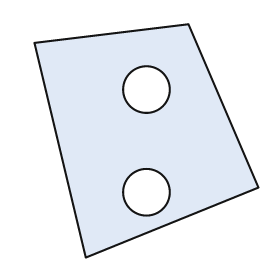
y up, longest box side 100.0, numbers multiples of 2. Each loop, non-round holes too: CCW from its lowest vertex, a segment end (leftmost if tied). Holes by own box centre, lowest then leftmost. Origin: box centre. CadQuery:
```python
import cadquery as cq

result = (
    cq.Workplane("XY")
    .moveTo(-26.0, -50.0)
    .lineTo(48.0, -20.0)
    .lineTo(18.0, 50.0)
    .lineTo(-48.0, 42.0)
    .close()
    .moveTo(0.0, -22.0)
    .circle(10.0)
    .moveTo(0.0, 22.0)
    .circle(10.0)
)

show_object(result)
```